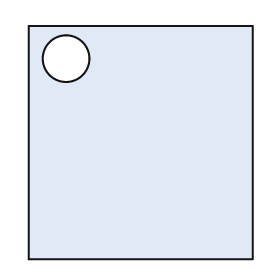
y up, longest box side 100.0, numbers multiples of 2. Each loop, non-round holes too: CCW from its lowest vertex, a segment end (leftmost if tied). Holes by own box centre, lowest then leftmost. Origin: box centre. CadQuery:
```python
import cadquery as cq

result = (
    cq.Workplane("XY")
    .moveTo(-48.0, -50.0)
    .lineTo(48.0, -50.0)
    .lineTo(48.0, 50.0)
    .lineTo(-48.0, 50.0)
    .close()
    .moveTo(-32.0, 36.0)
    .circle(10.0)
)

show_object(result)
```